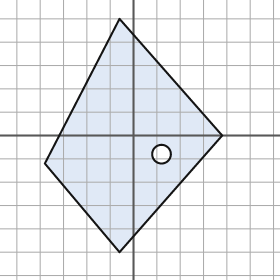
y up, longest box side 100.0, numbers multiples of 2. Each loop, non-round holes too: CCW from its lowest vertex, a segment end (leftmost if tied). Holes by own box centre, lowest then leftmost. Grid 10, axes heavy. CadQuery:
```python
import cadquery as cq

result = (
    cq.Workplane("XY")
    .moveTo(-6.0, -50.0)
    .lineTo(38.0, 0.0)
    .lineTo(-6.0, 50.0)
    .lineTo(-38.0, -12.0)
    .close()
    .moveTo(12.0, -8.0)
    .circle(4.0)
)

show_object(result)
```